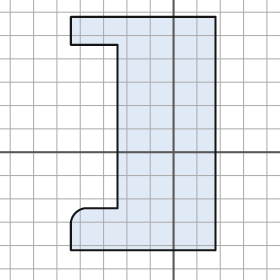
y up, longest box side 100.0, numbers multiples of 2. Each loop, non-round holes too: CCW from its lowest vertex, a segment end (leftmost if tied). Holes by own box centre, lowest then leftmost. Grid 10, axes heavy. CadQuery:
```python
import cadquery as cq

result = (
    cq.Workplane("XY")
    .moveTo(-44.0, -42.0)
    .lineTo(18.0, -42.0)
    .lineTo(18.0, 58.0)
    .lineTo(-44.0, 58.0)
    .lineTo(-44.0, 46.0)
    .lineTo(-24.0, 46.0)
    .lineTo(-24.0, -24.0)
    .lineTo(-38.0, -24.0)
    .threePointArc((-42.0, -26.0), (-44.0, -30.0))
    .close()
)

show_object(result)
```